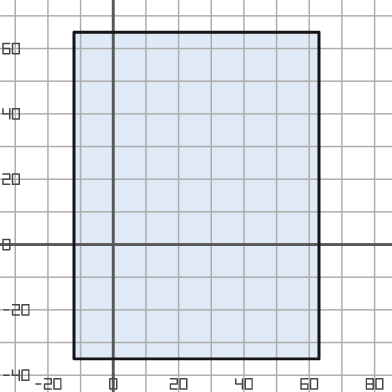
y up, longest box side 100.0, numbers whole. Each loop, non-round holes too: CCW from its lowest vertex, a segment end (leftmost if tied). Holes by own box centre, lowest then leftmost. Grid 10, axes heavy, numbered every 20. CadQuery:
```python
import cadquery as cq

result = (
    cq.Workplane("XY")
    .moveTo(-12.0, -35.0)
    .lineTo(63.0, -35.0)
    .lineTo(63.0, 65.0)
    .lineTo(-12.0, 65.0)
    .close()
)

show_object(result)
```